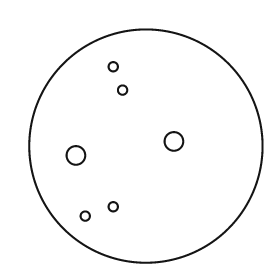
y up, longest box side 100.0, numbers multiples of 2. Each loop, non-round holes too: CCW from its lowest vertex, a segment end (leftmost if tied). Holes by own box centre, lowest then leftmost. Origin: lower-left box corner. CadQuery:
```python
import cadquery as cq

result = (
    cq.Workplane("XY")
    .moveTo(50.0, 50.0)
    .circle(50.0)
    .moveTo(24.0, 20.0)
    .circle(2.0)
    .moveTo(36.0, 24.0)
    .circle(2.0)
    .moveTo(20.0, 46.0)
    .circle(4.0)
    .moveTo(62.0, 52.0)
    .circle(4.0)
    .moveTo(40.0, 74.0)
    .circle(2.0)
    .moveTo(36.0, 84.0)
    .circle(2.0)
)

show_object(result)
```